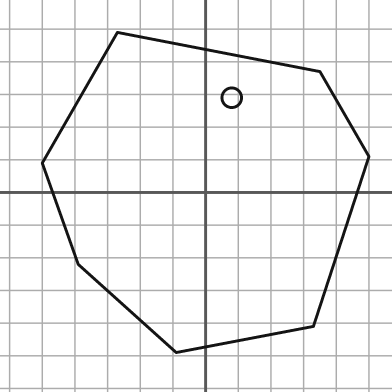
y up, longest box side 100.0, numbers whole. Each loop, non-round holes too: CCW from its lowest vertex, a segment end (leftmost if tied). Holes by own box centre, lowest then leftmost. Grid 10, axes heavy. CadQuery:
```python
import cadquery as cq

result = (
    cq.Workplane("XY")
    .moveTo(-9.0, -49.0)
    .lineTo(33.0, -41.0)
    .lineTo(50.0, 11.0)
    .lineTo(35.0, 37.0)
    .lineTo(-27.0, 49.0)
    .lineTo(-50.0, 9.0)
    .lineTo(-39.0, -22.0)
    .close()
    .moveTo(8.0, 29.0)
    .circle(3.0)
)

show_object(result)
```